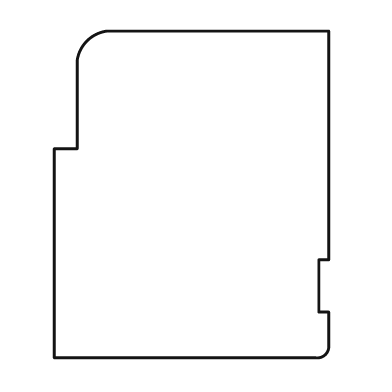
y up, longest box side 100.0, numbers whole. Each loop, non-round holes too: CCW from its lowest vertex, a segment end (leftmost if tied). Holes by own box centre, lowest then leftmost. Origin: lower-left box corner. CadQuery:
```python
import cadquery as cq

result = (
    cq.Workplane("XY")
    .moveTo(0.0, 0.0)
    .lineTo(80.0, 0.0)
    .threePointArc((83.0, 1.0), (84.0, 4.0))
    .lineTo(84.0, 14.0)
    .lineTo(81.0, 14.0)
    .lineTo(81.0, 30.0)
    .lineTo(84.0, 30.0)
    .lineTo(84.0, 100.0)
    .lineTo(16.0, 100.0)
    .threePointArc((10.0, 97.0), (7.0, 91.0))
    .lineTo(7.0, 64.0)
    .lineTo(0.0, 64.0)
    .close()
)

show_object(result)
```